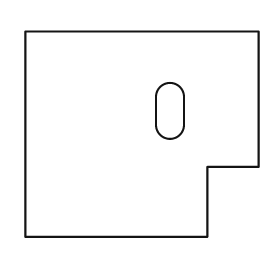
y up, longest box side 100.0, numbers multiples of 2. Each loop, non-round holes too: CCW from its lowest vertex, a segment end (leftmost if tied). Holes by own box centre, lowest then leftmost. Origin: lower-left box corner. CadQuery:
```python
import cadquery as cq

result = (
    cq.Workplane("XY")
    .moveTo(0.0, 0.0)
    .lineTo(78.0, 0.0)
    .lineTo(78.0, 30.0)
    .lineTo(100.0, 30.0)
    .lineTo(100.0, 88.0)
    .lineTo(0.0, 88.0)
    .close()
    .moveTo(56.0, 48.0)
    .threePointArc((62.0, 42.0), (68.0, 48.0))
    .lineTo(68.0, 60.0)
    .threePointArc((62.0, 66.0), (56.0, 60.0))
    .close()
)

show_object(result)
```